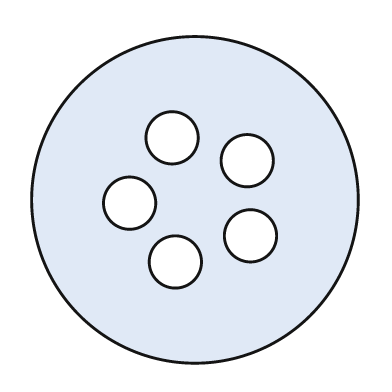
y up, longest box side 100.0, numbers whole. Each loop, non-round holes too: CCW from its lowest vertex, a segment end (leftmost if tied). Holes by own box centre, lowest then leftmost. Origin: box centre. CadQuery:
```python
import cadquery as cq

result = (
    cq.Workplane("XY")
    .moveTo(0.0, 0.0)
    .circle(50.0)
    .moveTo(-6.0, -19.0)
    .circle(8.0)
    .moveTo(17.0, -11.0)
    .circle(8.0)
    .moveTo(-20.0, -1.0)
    .circle(8.0)
    .moveTo(16.0, 12.0)
    .circle(8.0)
    .moveTo(-7.0, 19.0)
    .circle(8.0)
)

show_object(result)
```